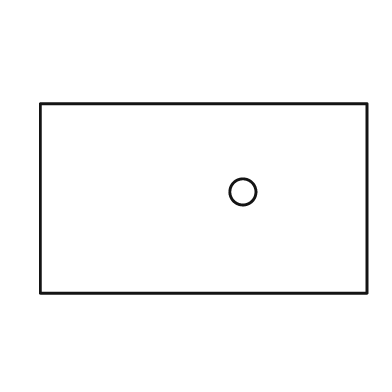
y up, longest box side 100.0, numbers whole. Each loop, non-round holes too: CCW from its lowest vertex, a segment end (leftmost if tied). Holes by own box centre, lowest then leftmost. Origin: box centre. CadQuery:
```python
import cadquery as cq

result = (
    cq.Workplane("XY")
    .moveTo(-50.0, -29.0)
    .lineTo(50.0, -29.0)
    .lineTo(50.0, 29.0)
    .lineTo(-50.0, 29.0)
    .close()
    .moveTo(12.0, 2.0)
    .circle(4.0)
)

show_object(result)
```